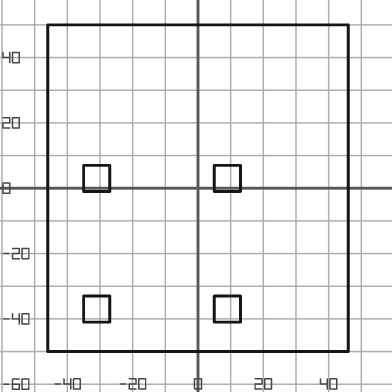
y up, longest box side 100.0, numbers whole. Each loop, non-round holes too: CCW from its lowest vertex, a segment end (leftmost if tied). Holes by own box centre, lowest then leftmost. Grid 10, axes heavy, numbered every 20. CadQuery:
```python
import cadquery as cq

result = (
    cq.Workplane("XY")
    .moveTo(-46.0, -50.0)
    .lineTo(46.0, -50.0)
    .lineTo(46.0, 50.0)
    .lineTo(-46.0, 50.0)
    .close()
    .moveTo(-35.0, -41.0)
    .lineTo(-27.0, -41.0)
    .lineTo(-27.0, -33.0)
    .lineTo(-35.0, -33.0)
    .close()
    .moveTo(5.0, -41.0)
    .lineTo(13.0, -41.0)
    .lineTo(13.0, -33.0)
    .lineTo(5.0, -33.0)
    .close()
    .moveTo(-35.0, -1.0)
    .lineTo(-27.0, -1.0)
    .lineTo(-27.0, 7.0)
    .lineTo(-35.0, 7.0)
    .close()
    .moveTo(5.0, -1.0)
    .lineTo(13.0, -1.0)
    .lineTo(13.0, 7.0)
    .lineTo(5.0, 7.0)
    .close()
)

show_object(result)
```